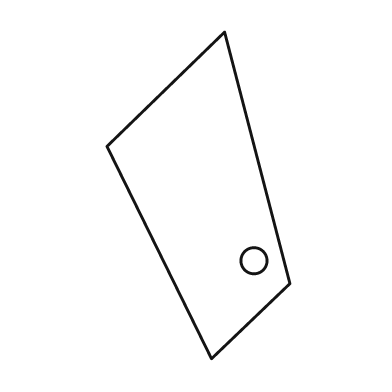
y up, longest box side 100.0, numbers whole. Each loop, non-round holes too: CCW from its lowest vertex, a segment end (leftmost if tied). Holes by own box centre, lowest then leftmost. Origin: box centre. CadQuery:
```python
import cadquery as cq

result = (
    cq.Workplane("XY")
    .moveTo(4.0, -50.0)
    .lineTo(28.0, -27.0)
    .lineTo(8.0, 50.0)
    .lineTo(-28.0, 15.0)
    .close()
    .moveTo(17.0, -20.0)
    .circle(4.0)
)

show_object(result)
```